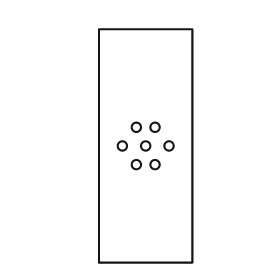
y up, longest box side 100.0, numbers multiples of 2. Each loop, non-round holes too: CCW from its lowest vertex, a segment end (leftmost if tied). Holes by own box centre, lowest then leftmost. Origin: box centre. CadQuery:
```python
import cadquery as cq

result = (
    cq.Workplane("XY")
    .moveTo(-20.0, -50.0)
    .lineTo(20.0, -50.0)
    .lineTo(20.0, 50.0)
    .lineTo(-20.0, 50.0)
    .close()
    .moveTo(-4.0, -8.0)
    .circle(2.0)
    .moveTo(4.0, -8.0)
    .circle(2.0)
    .moveTo(-10.0, 0.0)
    .circle(2.0)
    .moveTo(0.0, 0.0)
    .circle(2.0)
    .moveTo(10.0, 0.0)
    .circle(2.0)
    .moveTo(-4.0, 8.0)
    .circle(2.0)
    .moveTo(4.0, 8.0)
    .circle(2.0)
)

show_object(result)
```